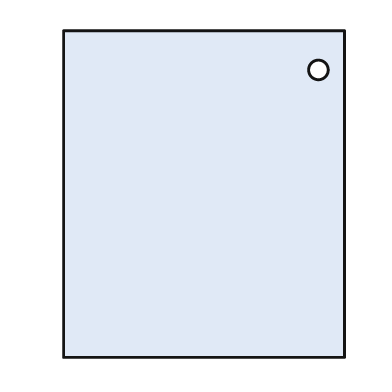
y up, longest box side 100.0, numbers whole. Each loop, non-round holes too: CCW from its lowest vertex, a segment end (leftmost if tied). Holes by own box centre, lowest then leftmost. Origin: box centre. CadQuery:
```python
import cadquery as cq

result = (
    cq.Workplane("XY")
    .moveTo(-43.0, -50.0)
    .lineTo(43.0, -50.0)
    .lineTo(43.0, 50.0)
    .lineTo(-43.0, 50.0)
    .close()
    .moveTo(35.0, 38.0)
    .circle(3.0)
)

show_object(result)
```